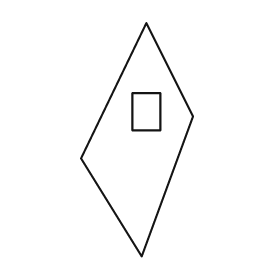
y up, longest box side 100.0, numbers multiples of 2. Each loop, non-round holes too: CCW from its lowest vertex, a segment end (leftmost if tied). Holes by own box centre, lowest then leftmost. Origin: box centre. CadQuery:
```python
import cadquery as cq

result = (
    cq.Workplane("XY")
    .moveTo(2.0, -50.0)
    .lineTo(24.0, 10.0)
    .lineTo(4.0, 50.0)
    .lineTo(-24.0, -8.0)
    .close()
    .moveTo(-2.0, 4.0)
    .lineTo(10.0, 4.0)
    .lineTo(10.0, 20.0)
    .lineTo(-2.0, 20.0)
    .close()
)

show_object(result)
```